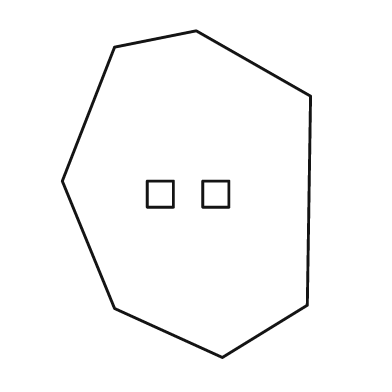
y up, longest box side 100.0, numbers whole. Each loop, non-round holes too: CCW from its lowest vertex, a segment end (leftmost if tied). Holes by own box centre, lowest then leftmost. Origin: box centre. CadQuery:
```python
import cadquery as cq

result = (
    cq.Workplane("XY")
    .moveTo(11.0, -50.0)
    .lineTo(37.0, -34.0)
    .lineTo(38.0, 30.0)
    .lineTo(3.0, 50.0)
    .lineTo(-22.0, 45.0)
    .lineTo(-38.0, 4.0)
    .lineTo(-22.0, -35.0)
    .close()
    .moveTo(-12.0, -4.0)
    .lineTo(-4.0, -4.0)
    .lineTo(-4.0, 4.0)
    .lineTo(-12.0, 4.0)
    .close()
    .moveTo(5.0, -4.0)
    .lineTo(13.0, -4.0)
    .lineTo(13.0, 4.0)
    .lineTo(5.0, 4.0)
    .close()
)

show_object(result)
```